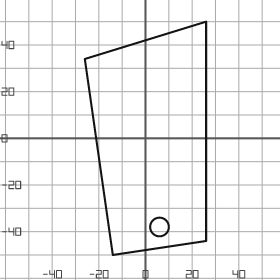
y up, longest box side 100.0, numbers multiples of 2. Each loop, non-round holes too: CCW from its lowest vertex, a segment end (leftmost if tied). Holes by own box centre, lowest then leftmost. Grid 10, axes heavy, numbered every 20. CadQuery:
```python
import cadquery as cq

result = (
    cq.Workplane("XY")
    .moveTo(-14.0, -50.0)
    .lineTo(26.0, -44.0)
    .lineTo(26.0, 50.0)
    .lineTo(-26.0, 34.0)
    .close()
    .moveTo(6.0, -38.0)
    .circle(4.0)
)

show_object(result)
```